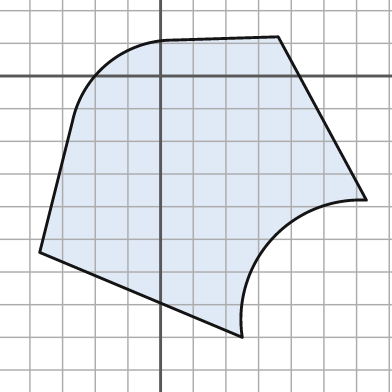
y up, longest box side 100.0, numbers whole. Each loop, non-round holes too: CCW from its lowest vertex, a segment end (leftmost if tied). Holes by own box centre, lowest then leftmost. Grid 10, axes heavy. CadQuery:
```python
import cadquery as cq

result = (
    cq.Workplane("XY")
    .moveTo(25.0, -80.0)
    .threePointArc((34.0, -50.0), (63.0, -38.0))
    .lineTo(36.0, 12.0)
    .lineTo(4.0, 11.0)
    .threePointArc((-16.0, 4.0), (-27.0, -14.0))
    .lineTo(-37.0, -54.0)
    .close()
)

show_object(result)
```